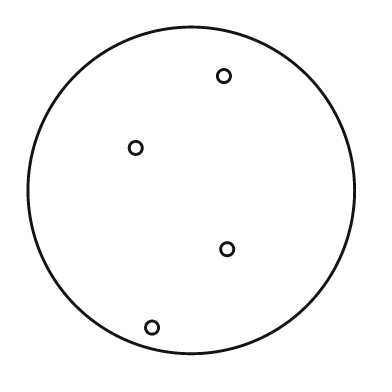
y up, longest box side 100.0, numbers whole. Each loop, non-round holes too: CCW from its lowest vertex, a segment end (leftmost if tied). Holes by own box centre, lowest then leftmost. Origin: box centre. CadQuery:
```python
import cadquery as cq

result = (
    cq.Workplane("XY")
    .moveTo(0.0, 0.0)
    .circle(50.0)
    .moveTo(-12.0, -42.0)
    .circle(2.0)
    .moveTo(11.0, -18.0)
    .circle(2.0)
    .moveTo(-17.0, 13.0)
    .circle(2.0)
    .moveTo(10.0, 35.0)
    .circle(2.0)
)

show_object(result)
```